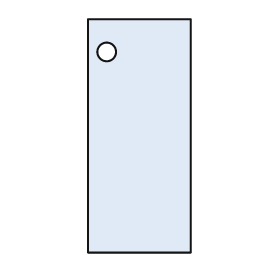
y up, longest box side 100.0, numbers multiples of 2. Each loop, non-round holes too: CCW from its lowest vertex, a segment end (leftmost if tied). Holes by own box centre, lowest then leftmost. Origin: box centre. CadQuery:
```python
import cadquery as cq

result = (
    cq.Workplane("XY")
    .moveTo(-22.0, -50.0)
    .lineTo(22.0, -50.0)
    .lineTo(22.0, 50.0)
    .lineTo(-22.0, 50.0)
    .close()
    .moveTo(-14.0, 36.0)
    .circle(4.0)
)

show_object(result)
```